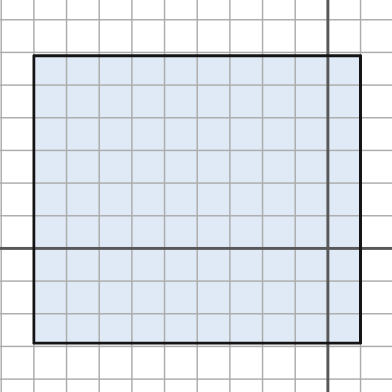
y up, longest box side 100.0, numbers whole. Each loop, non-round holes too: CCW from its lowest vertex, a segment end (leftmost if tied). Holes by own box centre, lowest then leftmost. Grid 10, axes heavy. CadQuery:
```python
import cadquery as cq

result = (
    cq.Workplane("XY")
    .moveTo(-90.0, -29.0)
    .lineTo(10.0, -29.0)
    .lineTo(10.0, 59.0)
    .lineTo(-90.0, 59.0)
    .close()
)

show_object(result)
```